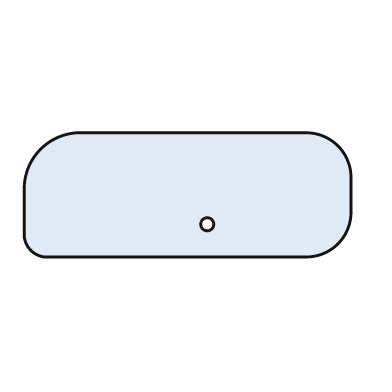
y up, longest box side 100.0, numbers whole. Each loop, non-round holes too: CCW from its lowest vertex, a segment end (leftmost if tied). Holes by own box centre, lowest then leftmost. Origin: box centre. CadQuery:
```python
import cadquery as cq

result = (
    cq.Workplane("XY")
    .moveTo(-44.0, -19.0)
    .lineTo(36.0, -19.0)
    .threePointArc((46.0, -15.0), (50.0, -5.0))
    .lineTo(50.0, 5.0)
    .threePointArc((46.0, 15.0), (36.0, 19.0))
    .lineTo(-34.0, 19.0)
    .threePointArc((-45.0, 14.0), (-50.0, 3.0))
    .lineTo(-50.0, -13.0)
    .threePointArc((-48.0, -17.0), (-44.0, -19.0))
    .close()
    .moveTo(6.0, -9.0)
    .circle(2.0)
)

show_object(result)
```